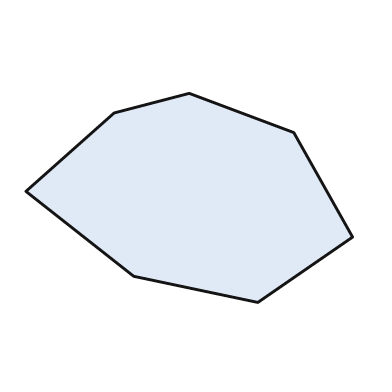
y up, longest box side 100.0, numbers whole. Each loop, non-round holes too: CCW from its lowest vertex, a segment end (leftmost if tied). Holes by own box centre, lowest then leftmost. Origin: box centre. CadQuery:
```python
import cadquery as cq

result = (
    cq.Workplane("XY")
    .moveTo(21.0, -32.0)
    .lineTo(50.0, -12.0)
    .lineTo(32.0, 20.0)
    .lineTo(0.0, 32.0)
    .lineTo(-23.0, 26.0)
    .lineTo(-50.0, 2.0)
    .lineTo(-17.0, -24.0)
    .close()
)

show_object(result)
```